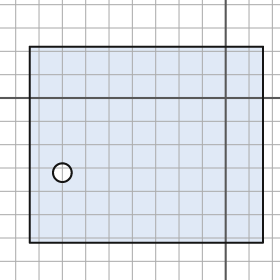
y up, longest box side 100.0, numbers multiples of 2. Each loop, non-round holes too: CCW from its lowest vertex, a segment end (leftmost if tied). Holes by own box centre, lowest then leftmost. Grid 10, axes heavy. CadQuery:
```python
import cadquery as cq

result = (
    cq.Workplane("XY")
    .moveTo(-84.0, -62.0)
    .lineTo(16.0, -62.0)
    .lineTo(16.0, 22.0)
    .lineTo(-84.0, 22.0)
    .close()
    .moveTo(-70.0, -32.0)
    .circle(4.0)
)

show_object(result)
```